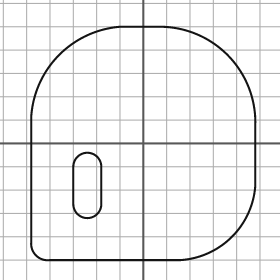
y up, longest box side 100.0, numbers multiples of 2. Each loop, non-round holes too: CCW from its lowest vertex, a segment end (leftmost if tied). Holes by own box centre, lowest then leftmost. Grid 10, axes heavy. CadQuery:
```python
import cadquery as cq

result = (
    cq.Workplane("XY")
    .moveTo(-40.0, -50.0)
    .lineTo(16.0, -50.0)
    .threePointArc((38.0, -40.0), (48.0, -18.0))
    .lineTo(48.0, 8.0)
    .threePointArc((36.0, 38.0), (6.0, 50.0))
    .lineTo(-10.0, 50.0)
    .threePointArc((-36.0, 38.0), (-48.0, 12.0))
    .lineTo(-48.0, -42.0)
    .threePointArc((-46.0, -48.0), (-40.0, -50.0))
    .close()
    .moveTo(-30.0, -26.0)
    .threePointArc((-24.0, -32.0), (-18.0, -26.0))
    .lineTo(-18.0, -10.0)
    .threePointArc((-24.0, -4.0), (-30.0, -10.0))
    .close()
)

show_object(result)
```